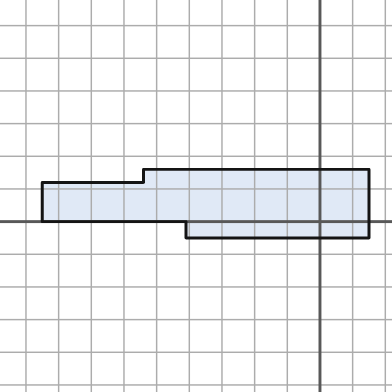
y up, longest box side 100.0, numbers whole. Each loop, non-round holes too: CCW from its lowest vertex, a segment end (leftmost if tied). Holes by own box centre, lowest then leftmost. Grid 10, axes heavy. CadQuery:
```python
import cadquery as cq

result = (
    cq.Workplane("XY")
    .moveTo(-41.0, -5.0)
    .lineTo(15.0, -5.0)
    .lineTo(15.0, 16.0)
    .lineTo(-54.0, 16.0)
    .lineTo(-54.0, 12.0)
    .lineTo(-85.0, 12.0)
    .lineTo(-85.0, 0.0)
    .lineTo(-41.0, 0.0)
    .close()
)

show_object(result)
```